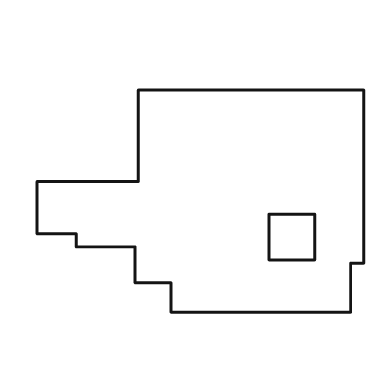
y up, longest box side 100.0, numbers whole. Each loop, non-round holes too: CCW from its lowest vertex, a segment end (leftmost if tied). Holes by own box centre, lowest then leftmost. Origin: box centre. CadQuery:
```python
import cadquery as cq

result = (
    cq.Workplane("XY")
    .moveTo(-9.0, -34.0)
    .lineTo(46.0, -34.0)
    .lineTo(46.0, -19.0)
    .lineTo(50.0, -19.0)
    .lineTo(50.0, 34.0)
    .lineTo(-19.0, 34.0)
    .lineTo(-19.0, 6.0)
    .lineTo(-50.0, 6.0)
    .lineTo(-50.0, -10.0)
    .lineTo(-38.0, -10.0)
    .lineTo(-38.0, -14.0)
    .lineTo(-20.0, -14.0)
    .lineTo(-20.0, -25.0)
    .lineTo(-9.0, -25.0)
    .close()
    .moveTo(21.0, -18.0)
    .lineTo(35.0, -18.0)
    .lineTo(35.0, -4.0)
    .lineTo(21.0, -4.0)
    .close()
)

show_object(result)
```